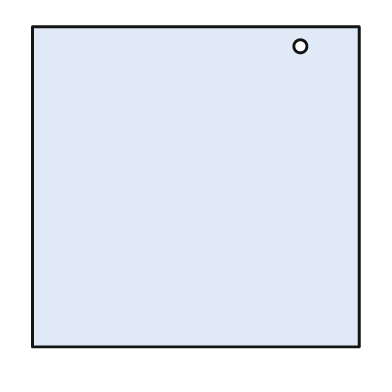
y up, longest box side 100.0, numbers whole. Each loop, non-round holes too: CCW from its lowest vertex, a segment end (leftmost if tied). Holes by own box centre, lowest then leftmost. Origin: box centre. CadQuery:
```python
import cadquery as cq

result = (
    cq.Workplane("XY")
    .moveTo(-50.0, -49.0)
    .lineTo(50.0, -49.0)
    .lineTo(50.0, 49.0)
    .lineTo(-50.0, 49.0)
    .close()
    .moveTo(32.0, 43.0)
    .circle(2.0)
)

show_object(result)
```